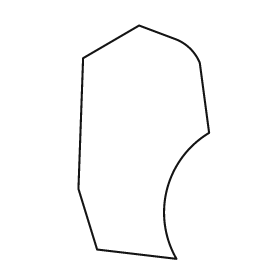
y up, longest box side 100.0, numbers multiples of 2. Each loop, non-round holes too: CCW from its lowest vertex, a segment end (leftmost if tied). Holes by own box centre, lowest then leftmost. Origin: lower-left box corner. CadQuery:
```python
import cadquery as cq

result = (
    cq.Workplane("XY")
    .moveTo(42.0, 0.0)
    .threePointArc((38.0, 30.0), (56.0, 54.0))
    .lineTo(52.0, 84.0)
    .threePointArc((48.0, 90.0), (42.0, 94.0))
    .lineTo(26.0, 100.0)
    .lineTo(2.0, 86.0)
    .lineTo(0.0, 30.0)
    .lineTo(8.0, 4.0)
    .close()
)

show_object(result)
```